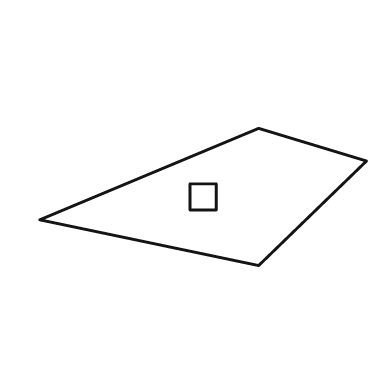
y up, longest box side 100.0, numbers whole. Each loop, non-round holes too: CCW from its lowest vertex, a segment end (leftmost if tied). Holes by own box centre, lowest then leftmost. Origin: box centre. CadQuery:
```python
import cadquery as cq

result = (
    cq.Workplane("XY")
    .moveTo(17.0, -21.0)
    .lineTo(50.0, 11.0)
    .lineTo(17.0, 21.0)
    .lineTo(-50.0, -7.0)
    .close()
    .moveTo(-4.0, -4.0)
    .lineTo(4.0, -4.0)
    .lineTo(4.0, 4.0)
    .lineTo(-4.0, 4.0)
    .close()
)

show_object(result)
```